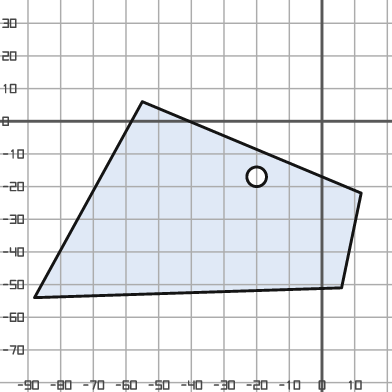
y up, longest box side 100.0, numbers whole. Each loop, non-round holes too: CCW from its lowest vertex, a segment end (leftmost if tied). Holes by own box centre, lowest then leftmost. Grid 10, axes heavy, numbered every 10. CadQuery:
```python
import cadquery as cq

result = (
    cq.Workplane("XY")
    .moveTo(-88.0, -54.0)
    .lineTo(6.0, -51.0)
    .lineTo(12.0, -22.0)
    .lineTo(-55.0, 6.0)
    .close()
    .moveTo(-20.0, -17.0)
    .circle(3.0)
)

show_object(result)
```